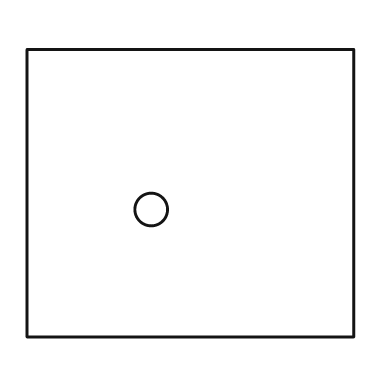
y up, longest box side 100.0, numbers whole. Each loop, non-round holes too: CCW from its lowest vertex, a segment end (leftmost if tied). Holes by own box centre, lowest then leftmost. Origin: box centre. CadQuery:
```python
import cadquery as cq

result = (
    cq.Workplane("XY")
    .moveTo(-50.0, -44.0)
    .lineTo(50.0, -44.0)
    .lineTo(50.0, 44.0)
    .lineTo(-50.0, 44.0)
    .close()
    .moveTo(-12.0, -5.0)
    .circle(5.0)
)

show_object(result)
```